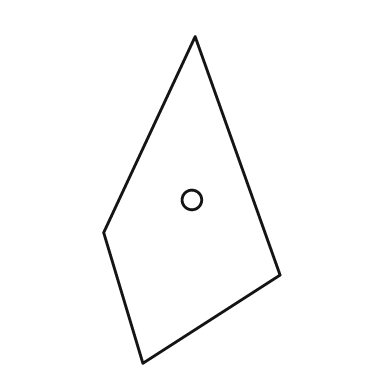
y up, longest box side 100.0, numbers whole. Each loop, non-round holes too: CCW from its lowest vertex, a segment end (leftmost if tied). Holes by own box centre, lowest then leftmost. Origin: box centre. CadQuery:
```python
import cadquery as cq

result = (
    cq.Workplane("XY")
    .moveTo(-15.0, -50.0)
    .lineTo(27.0, -23.0)
    .lineTo(1.0, 50.0)
    .lineTo(-27.0, -10.0)
    .close()
    .moveTo(0.0, 0.0)
    .circle(3.0)
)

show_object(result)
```